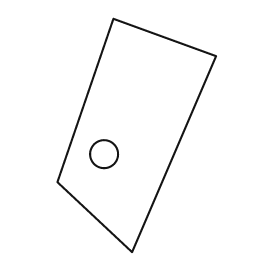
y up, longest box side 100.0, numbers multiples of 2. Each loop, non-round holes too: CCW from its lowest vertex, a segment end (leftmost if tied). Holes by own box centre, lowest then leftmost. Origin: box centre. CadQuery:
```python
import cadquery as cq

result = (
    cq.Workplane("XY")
    .moveTo(-2.0, -50.0)
    .lineTo(34.0, 34.0)
    .lineTo(-10.0, 50.0)
    .lineTo(-34.0, -20.0)
    .close()
    .moveTo(-14.0, -8.0)
    .circle(6.0)
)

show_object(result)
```